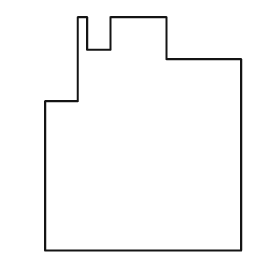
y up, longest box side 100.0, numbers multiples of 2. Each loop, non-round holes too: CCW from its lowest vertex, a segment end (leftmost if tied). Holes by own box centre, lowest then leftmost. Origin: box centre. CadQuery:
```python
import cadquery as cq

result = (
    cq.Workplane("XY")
    .moveTo(-42.0, -50.0)
    .lineTo(42.0, -50.0)
    .lineTo(42.0, 32.0)
    .lineTo(10.0, 32.0)
    .lineTo(10.0, 50.0)
    .lineTo(-14.0, 50.0)
    .lineTo(-14.0, 36.0)
    .lineTo(-24.0, 36.0)
    .lineTo(-24.0, 50.0)
    .lineTo(-28.0, 50.0)
    .lineTo(-28.0, 14.0)
    .lineTo(-42.0, 14.0)
    .close()
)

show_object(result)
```